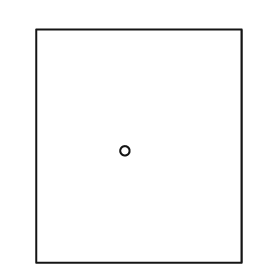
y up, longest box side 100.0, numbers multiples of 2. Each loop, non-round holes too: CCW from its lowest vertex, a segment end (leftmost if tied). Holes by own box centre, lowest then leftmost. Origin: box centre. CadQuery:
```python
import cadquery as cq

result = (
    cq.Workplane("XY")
    .moveTo(-44.0, -50.0)
    .lineTo(44.0, -50.0)
    .lineTo(44.0, 50.0)
    .lineTo(-44.0, 50.0)
    .close()
    .moveTo(-6.0, -2.0)
    .circle(2.0)
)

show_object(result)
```